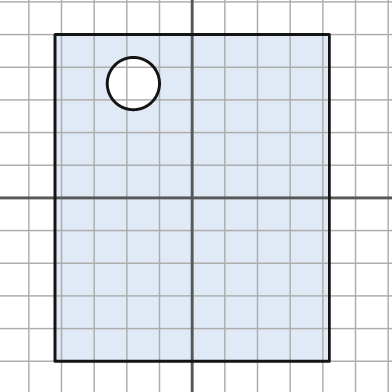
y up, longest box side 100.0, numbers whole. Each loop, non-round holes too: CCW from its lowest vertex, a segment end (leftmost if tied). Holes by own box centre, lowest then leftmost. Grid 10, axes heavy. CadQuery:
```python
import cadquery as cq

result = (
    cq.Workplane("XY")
    .moveTo(-42.0, -50.0)
    .lineTo(42.0, -50.0)
    .lineTo(42.0, 50.0)
    .lineTo(-42.0, 50.0)
    .close()
    .moveTo(-18.0, 35.0)
    .circle(8.0)
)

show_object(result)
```